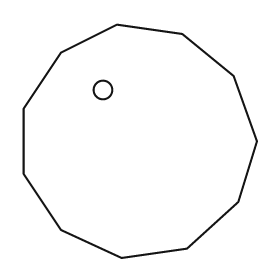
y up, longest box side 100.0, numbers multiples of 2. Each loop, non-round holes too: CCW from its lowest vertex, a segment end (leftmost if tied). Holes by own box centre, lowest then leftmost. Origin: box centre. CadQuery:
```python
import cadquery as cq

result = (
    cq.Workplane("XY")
    .moveTo(-8.0, -50.0)
    .lineTo(20.0, -46.0)
    .lineTo(42.0, -26.0)
    .lineTo(50.0, 0.0)
    .lineTo(40.0, 28.0)
    .lineTo(18.0, 46.0)
    .lineTo(-10.0, 50.0)
    .lineTo(-34.0, 38.0)
    .lineTo(-50.0, 14.0)
    .lineTo(-50.0, -14.0)
    .lineTo(-34.0, -38.0)
    .close()
    .moveTo(-16.0, 22.0)
    .circle(4.0)
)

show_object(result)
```